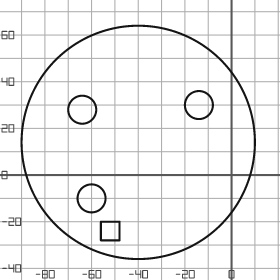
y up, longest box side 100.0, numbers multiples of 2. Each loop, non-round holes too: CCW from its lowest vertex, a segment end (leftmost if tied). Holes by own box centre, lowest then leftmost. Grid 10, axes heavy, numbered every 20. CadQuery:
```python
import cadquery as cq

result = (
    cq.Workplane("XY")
    .moveTo(-40.0, 14.0)
    .circle(50.0)
    .moveTo(-56.0, -28.0)
    .lineTo(-48.0, -28.0)
    .lineTo(-48.0, -20.0)
    .lineTo(-56.0, -20.0)
    .close()
    .moveTo(-60.0, -10.0)
    .circle(6.0)
    .moveTo(-64.0, 28.0)
    .circle(6.0)
    .moveTo(-14.0, 30.0)
    .circle(6.0)
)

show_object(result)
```